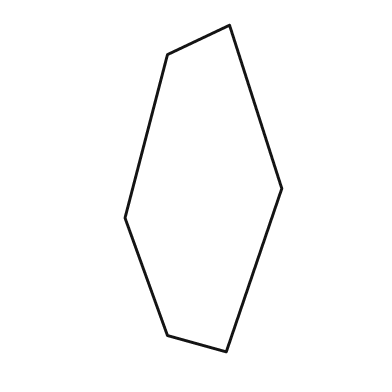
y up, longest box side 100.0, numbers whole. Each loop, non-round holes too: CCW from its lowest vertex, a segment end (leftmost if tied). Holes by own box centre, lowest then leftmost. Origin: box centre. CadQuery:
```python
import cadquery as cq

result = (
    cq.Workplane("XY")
    .moveTo(7.0, -50.0)
    .lineTo(24.0, 0.0)
    .lineTo(8.0, 50.0)
    .lineTo(-11.0, 41.0)
    .lineTo(-24.0, -9.0)
    .lineTo(-11.0, -45.0)
    .close()
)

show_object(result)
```